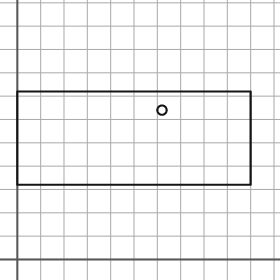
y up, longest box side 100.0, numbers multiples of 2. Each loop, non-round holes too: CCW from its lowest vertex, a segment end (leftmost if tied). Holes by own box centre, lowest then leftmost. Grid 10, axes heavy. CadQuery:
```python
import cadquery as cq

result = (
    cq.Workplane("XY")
    .moveTo(0.0, 32.0)
    .lineTo(100.0, 32.0)
    .lineTo(100.0, 72.0)
    .lineTo(0.0, 72.0)
    .close()
    .moveTo(62.0, 64.0)
    .circle(2.0)
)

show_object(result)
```